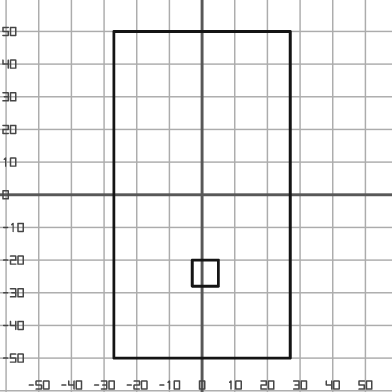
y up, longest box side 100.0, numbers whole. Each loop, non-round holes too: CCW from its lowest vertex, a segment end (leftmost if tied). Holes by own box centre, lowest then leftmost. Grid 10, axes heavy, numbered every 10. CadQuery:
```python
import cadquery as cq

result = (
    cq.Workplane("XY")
    .moveTo(-27.0, -50.0)
    .lineTo(27.0, -50.0)
    .lineTo(27.0, 50.0)
    .lineTo(-27.0, 50.0)
    .close()
    .moveTo(-3.0, -28.0)
    .lineTo(5.0, -28.0)
    .lineTo(5.0, -20.0)
    .lineTo(-3.0, -20.0)
    .close()
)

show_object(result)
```